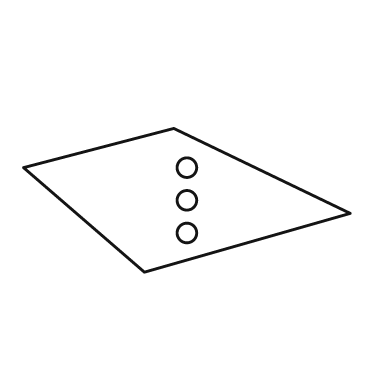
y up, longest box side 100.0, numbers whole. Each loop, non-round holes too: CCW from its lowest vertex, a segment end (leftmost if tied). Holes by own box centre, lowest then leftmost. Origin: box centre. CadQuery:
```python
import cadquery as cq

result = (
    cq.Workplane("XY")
    .moveTo(-13.0, -22.0)
    .lineTo(50.0, -4.0)
    .lineTo(-4.0, 22.0)
    .lineTo(-50.0, 10.0)
    .close()
    .moveTo(0.0, -10.0)
    .circle(3.0)
    .moveTo(0.0, 0.0)
    .circle(3.0)
    .moveTo(0.0, 10.0)
    .circle(3.0)
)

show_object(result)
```